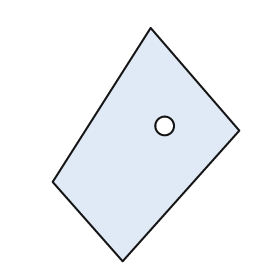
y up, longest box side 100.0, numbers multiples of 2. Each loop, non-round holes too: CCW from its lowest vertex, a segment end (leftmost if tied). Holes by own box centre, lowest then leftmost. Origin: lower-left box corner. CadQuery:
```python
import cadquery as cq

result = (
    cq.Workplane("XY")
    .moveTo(30.0, 0.0)
    .lineTo(80.0, 56.0)
    .lineTo(42.0, 100.0)
    .lineTo(0.0, 34.0)
    .close()
    .moveTo(48.0, 58.0)
    .circle(4.0)
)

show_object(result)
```